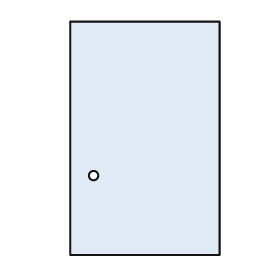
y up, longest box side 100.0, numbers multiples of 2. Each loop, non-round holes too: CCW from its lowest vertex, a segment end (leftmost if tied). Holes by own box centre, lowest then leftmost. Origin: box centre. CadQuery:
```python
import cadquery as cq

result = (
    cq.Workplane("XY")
    .moveTo(-32.0, -50.0)
    .lineTo(32.0, -50.0)
    .lineTo(32.0, 50.0)
    .lineTo(-32.0, 50.0)
    .close()
    .moveTo(-22.0, -16.0)
    .circle(2.0)
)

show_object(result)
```